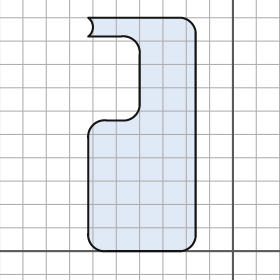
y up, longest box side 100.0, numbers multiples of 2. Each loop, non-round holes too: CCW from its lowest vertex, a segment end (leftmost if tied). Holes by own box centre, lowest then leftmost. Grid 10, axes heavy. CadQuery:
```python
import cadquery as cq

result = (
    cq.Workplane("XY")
    .moveTo(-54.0, 0.0)
    .lineTo(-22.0, 0.0)
    .threePointArc((-18.0, 2.0), (-16.0, 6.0))
    .lineTo(-16.0, 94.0)
    .threePointArc((-18.0, 98.0), (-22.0, 100.0))
    .lineTo(-62.0, 100.0)
    .threePointArc((-60.0, 96.0), (-62.0, 92.0))
    .lineTo(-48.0, 92.0)
    .threePointArc((-42.0, 90.0), (-40.0, 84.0))
    .lineTo(-40.0, 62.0)
    .threePointArc((-42.0, 58.0), (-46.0, 56.0))
    .lineTo(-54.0, 56.0)
    .threePointArc((-60.0, 54.0), (-62.0, 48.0))
    .lineTo(-62.0, 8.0)
    .threePointArc((-60.0, 2.0), (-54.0, 0.0))
    .close()
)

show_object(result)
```